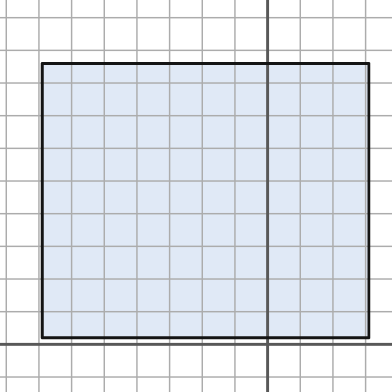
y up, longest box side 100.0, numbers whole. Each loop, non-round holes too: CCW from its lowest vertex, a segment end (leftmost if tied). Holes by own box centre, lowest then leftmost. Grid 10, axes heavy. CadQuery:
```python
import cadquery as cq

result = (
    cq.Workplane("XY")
    .moveTo(-69.0, 2.0)
    .lineTo(31.0, 2.0)
    .lineTo(31.0, 86.0)
    .lineTo(-69.0, 86.0)
    .close()
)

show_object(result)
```